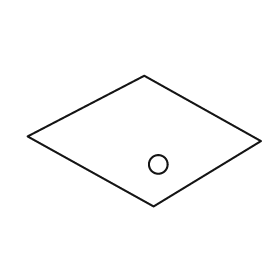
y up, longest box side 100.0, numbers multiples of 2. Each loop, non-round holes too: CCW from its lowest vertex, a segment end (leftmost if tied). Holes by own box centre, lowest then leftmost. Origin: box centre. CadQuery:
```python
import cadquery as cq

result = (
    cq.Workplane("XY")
    .moveTo(4.0, -28.0)
    .lineTo(50.0, 0.0)
    .lineTo(0.0, 28.0)
    .lineTo(-50.0, 2.0)
    .close()
    .moveTo(6.0, -10.0)
    .circle(4.0)
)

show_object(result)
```